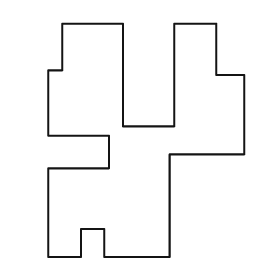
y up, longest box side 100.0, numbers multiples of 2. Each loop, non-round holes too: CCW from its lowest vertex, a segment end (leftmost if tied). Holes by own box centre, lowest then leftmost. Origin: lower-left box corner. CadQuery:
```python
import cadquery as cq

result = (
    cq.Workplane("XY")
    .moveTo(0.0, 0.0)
    .lineTo(14.0, 0.0)
    .lineTo(14.0, 12.0)
    .lineTo(24.0, 12.0)
    .lineTo(24.0, 0.0)
    .lineTo(52.0, 0.0)
    .lineTo(52.0, 44.0)
    .lineTo(84.0, 44.0)
    .lineTo(84.0, 78.0)
    .lineTo(72.0, 78.0)
    .lineTo(72.0, 100.0)
    .lineTo(54.0, 100.0)
    .lineTo(54.0, 56.0)
    .lineTo(32.0, 56.0)
    .lineTo(32.0, 100.0)
    .lineTo(6.0, 100.0)
    .lineTo(6.0, 80.0)
    .lineTo(0.0, 80.0)
    .lineTo(0.0, 52.0)
    .lineTo(26.0, 52.0)
    .lineTo(26.0, 38.0)
    .lineTo(0.0, 38.0)
    .close()
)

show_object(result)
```